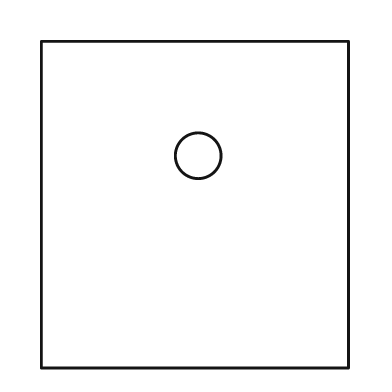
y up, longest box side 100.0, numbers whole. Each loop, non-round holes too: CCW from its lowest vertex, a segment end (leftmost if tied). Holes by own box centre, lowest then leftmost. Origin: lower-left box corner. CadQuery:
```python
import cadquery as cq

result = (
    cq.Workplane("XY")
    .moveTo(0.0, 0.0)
    .lineTo(94.0, 0.0)
    .lineTo(94.0, 100.0)
    .lineTo(0.0, 100.0)
    .close()
    .moveTo(48.0, 65.0)
    .circle(7.0)
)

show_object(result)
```